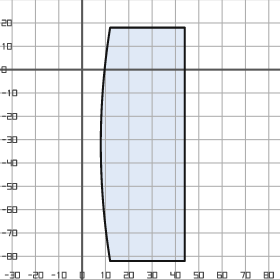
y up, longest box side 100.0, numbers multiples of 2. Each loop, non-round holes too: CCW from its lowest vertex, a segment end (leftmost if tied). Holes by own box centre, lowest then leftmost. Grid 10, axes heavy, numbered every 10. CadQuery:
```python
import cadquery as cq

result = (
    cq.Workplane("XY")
    .moveTo(12.0, -82.0)
    .lineTo(44.0, -82.0)
    .lineTo(44.0, 18.0)
    .lineTo(12.0, 18.0)
    .threePointArc((8.0, -32.0), (12.0, -82.0))
    .close()
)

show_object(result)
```